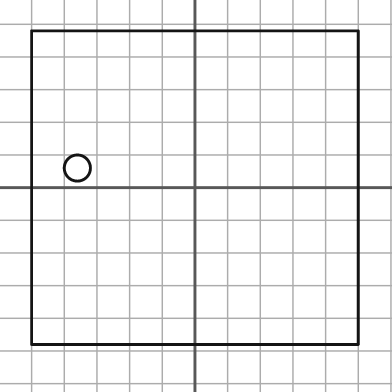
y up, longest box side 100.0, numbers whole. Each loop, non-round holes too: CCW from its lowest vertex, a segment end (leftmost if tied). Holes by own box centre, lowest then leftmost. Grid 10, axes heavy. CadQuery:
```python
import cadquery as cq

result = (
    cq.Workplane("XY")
    .moveTo(-50.0, -48.0)
    .lineTo(50.0, -48.0)
    .lineTo(50.0, 48.0)
    .lineTo(-50.0, 48.0)
    .close()
    .moveTo(-36.0, 6.0)
    .circle(4.0)
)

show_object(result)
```